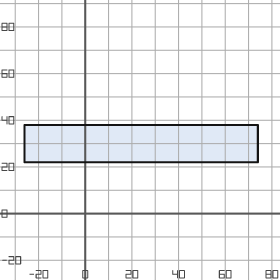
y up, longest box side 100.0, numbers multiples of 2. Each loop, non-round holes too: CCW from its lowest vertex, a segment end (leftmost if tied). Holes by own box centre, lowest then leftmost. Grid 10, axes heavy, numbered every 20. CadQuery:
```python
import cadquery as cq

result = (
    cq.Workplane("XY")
    .moveTo(-26.0, 22.0)
    .lineTo(74.0, 22.0)
    .lineTo(74.0, 38.0)
    .lineTo(-26.0, 38.0)
    .close()
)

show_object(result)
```